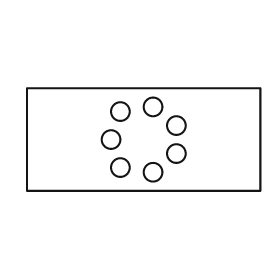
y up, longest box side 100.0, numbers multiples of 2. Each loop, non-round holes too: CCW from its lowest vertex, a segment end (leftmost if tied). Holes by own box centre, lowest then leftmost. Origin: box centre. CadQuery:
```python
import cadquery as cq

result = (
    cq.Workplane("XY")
    .moveTo(-50.0, -22.0)
    .lineTo(50.0, -22.0)
    .lineTo(50.0, 22.0)
    .lineTo(-50.0, 22.0)
    .close()
    .moveTo(4.0, -14.0)
    .circle(4.0)
    .moveTo(-10.0, -12.0)
    .circle(4.0)
    .moveTo(14.0, -6.0)
    .circle(4.0)
    .moveTo(-14.0, 0.0)
    .circle(4.0)
    .moveTo(14.0, 6.0)
    .circle(4.0)
    .moveTo(-10.0, 12.0)
    .circle(4.0)
    .moveTo(4.0, 14.0)
    .circle(4.0)
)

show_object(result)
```